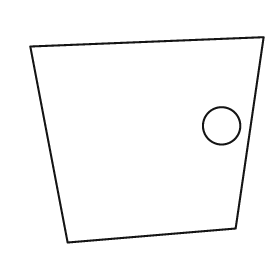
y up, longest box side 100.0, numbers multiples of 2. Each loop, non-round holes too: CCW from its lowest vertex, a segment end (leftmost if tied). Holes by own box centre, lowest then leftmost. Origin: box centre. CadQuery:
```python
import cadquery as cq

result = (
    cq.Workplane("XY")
    .moveTo(-34.0, -44.0)
    .lineTo(38.0, -38.0)
    .lineTo(50.0, 44.0)
    .lineTo(-50.0, 40.0)
    .close()
    .moveTo(32.0, 6.0)
    .circle(8.0)
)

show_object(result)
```